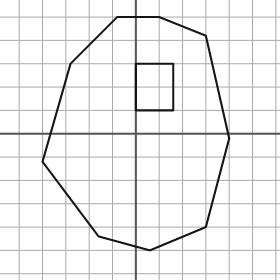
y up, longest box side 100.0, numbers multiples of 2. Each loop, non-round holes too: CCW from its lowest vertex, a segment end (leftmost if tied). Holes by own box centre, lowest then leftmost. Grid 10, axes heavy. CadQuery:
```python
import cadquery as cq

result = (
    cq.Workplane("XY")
    .moveTo(6.0, -50.0)
    .lineTo(30.0, -40.0)
    .lineTo(40.0, -2.0)
    .lineTo(30.0, 42.0)
    .lineTo(10.0, 50.0)
    .lineTo(-8.0, 50.0)
    .lineTo(-28.0, 30.0)
    .lineTo(-40.0, -12.0)
    .lineTo(-16.0, -44.0)
    .close()
    .moveTo(0.0, 10.0)
    .lineTo(16.0, 10.0)
    .lineTo(16.0, 30.0)
    .lineTo(0.0, 30.0)
    .close()
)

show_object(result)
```